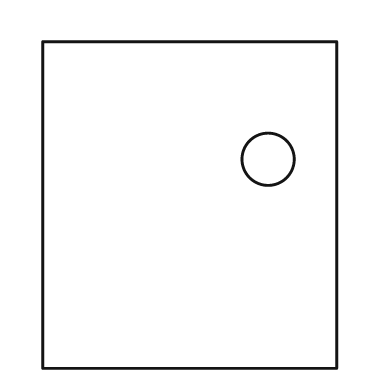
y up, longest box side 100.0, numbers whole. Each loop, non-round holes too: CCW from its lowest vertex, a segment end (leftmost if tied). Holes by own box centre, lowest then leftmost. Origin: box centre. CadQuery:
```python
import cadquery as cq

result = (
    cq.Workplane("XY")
    .moveTo(-45.0, -50.0)
    .lineTo(45.0, -50.0)
    .lineTo(45.0, 50.0)
    .lineTo(-45.0, 50.0)
    .close()
    .moveTo(24.0, 14.0)
    .circle(8.0)
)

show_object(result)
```